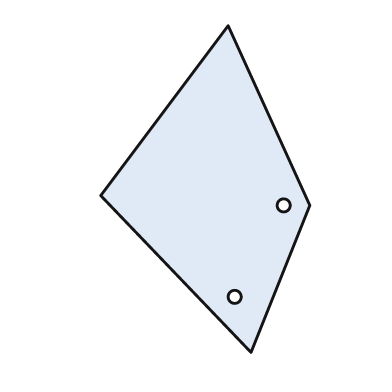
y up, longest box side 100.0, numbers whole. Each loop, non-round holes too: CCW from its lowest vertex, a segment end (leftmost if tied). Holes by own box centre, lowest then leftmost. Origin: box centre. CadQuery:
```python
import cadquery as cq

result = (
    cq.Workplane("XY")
    .moveTo(14.0, -50.0)
    .lineTo(32.0, -5.0)
    .lineTo(7.0, 50.0)
    .lineTo(-32.0, -2.0)
    .close()
    .moveTo(9.0, -33.0)
    .circle(2.0)
    .moveTo(24.0, -5.0)
    .circle(2.0)
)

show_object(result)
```